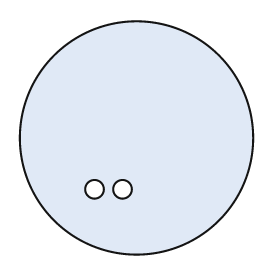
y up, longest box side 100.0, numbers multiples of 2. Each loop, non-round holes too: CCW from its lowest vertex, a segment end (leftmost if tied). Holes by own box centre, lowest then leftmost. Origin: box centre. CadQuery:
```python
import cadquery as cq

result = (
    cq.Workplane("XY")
    .moveTo(0.0, 0.0)
    .circle(50.0)
    .moveTo(-18.0, -22.0)
    .circle(4.0)
    .moveTo(-6.0, -22.0)
    .circle(4.0)
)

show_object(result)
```